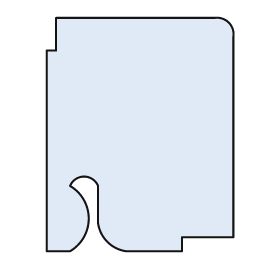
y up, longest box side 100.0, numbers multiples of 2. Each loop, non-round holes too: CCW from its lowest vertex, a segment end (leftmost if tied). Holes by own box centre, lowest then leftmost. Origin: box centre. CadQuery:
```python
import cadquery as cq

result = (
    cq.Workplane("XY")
    .moveTo(-40.0, -50.0)
    .lineTo(-30.0, -50.0)
    .threePointArc((-22.0, -36.0), (-30.0, -22.0))
    .threePointArc((-24.0, -18.0), (-18.0, -22.0))
    .lineTo(-18.0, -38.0)
    .threePointArc((-14.0, -46.0), (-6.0, -50.0))
    .lineTo(18.0, -50.0)
    .lineTo(18.0, -44.0)
    .lineTo(40.0, -44.0)
    .lineTo(40.0, 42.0)
    .threePointArc((38.0, 48.0), (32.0, 50.0))
    .lineTo(-36.0, 50.0)
    .lineTo(-36.0, 36.0)
    .lineTo(-40.0, 36.0)
    .close()
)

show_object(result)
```